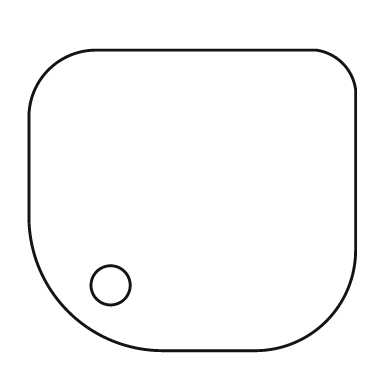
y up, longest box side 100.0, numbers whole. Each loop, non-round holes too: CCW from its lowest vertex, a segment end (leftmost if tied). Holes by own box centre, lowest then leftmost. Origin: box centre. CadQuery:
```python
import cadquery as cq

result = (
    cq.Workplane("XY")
    .moveTo(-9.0, -46.0)
    .lineTo(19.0, -46.0)
    .threePointArc((41.0, -37.0), (50.0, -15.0))
    .lineTo(50.0, 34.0)
    .threePointArc((46.0, 42.0), (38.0, 46.0))
    .lineTo(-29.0, 46.0)
    .threePointArc((-44.0, 40.0), (-50.0, 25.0))
    .lineTo(-50.0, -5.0)
    .threePointArc((-38.0, -34.0), (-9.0, -46.0))
    .close()
    .moveTo(-25.0, -26.0)
    .circle(6.0)
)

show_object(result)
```